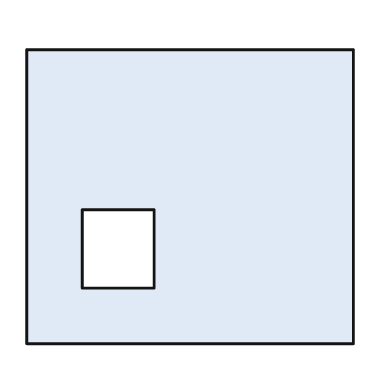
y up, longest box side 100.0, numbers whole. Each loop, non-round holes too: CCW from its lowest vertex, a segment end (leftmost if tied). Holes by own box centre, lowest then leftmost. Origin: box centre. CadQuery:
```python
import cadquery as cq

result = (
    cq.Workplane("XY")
    .moveTo(-50.0, -45.0)
    .lineTo(50.0, -45.0)
    .lineTo(50.0, 45.0)
    .lineTo(-50.0, 45.0)
    .close()
    .moveTo(-33.0, -28.0)
    .lineTo(-11.0, -28.0)
    .lineTo(-11.0, -4.0)
    .lineTo(-33.0, -4.0)
    .close()
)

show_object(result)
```